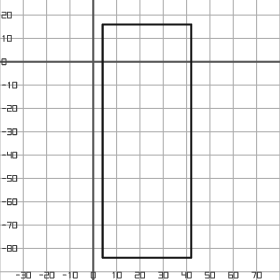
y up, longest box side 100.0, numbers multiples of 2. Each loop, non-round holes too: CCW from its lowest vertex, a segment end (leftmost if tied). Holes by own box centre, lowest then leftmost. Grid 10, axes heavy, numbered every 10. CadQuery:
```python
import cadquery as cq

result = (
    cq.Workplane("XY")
    .moveTo(4.0, -84.0)
    .lineTo(42.0, -84.0)
    .lineTo(42.0, 16.0)
    .lineTo(4.0, 16.0)
    .close()
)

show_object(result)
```